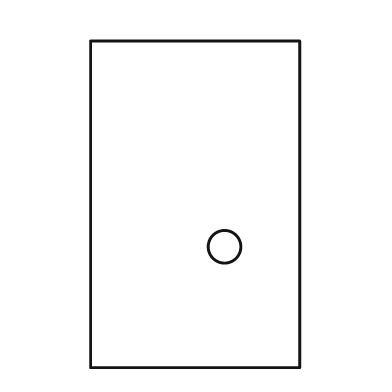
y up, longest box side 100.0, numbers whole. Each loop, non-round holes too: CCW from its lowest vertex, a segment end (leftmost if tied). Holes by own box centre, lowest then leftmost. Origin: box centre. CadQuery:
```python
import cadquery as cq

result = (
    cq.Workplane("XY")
    .moveTo(-32.0, -50.0)
    .lineTo(32.0, -50.0)
    .lineTo(32.0, 50.0)
    .lineTo(-32.0, 50.0)
    .close()
    .moveTo(9.0, -13.0)
    .circle(5.0)
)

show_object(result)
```